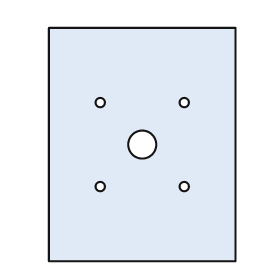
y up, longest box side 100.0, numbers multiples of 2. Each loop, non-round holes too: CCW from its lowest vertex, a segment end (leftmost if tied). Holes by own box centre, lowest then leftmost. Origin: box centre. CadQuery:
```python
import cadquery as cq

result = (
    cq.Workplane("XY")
    .moveTo(-40.0, -50.0)
    .lineTo(40.0, -50.0)
    .lineTo(40.0, 50.0)
    .lineTo(-40.0, 50.0)
    .close()
    .moveTo(-18.0, -18.0)
    .circle(2.0)
    .moveTo(18.0, -18.0)
    .circle(2.0)
    .moveTo(0.0, 0.0)
    .circle(6.0)
    .moveTo(-18.0, 18.0)
    .circle(2.0)
    .moveTo(18.0, 18.0)
    .circle(2.0)
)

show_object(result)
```